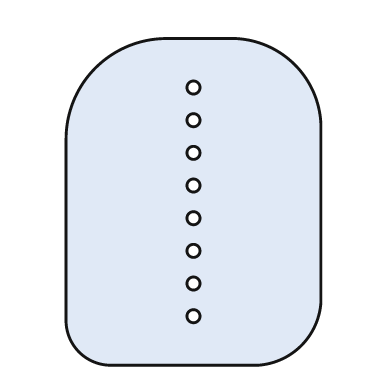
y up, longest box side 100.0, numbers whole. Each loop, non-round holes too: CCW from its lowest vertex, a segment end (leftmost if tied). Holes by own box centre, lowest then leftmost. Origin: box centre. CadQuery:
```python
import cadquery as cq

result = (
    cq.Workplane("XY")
    .moveTo(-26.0, -50.0)
    .lineTo(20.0, -50.0)
    .threePointArc((33.0, -44.0), (39.0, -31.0))
    .lineTo(39.0, 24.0)
    .threePointArc((31.0, 42.0), (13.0, 50.0))
    .lineTo(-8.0, 50.0)
    .threePointArc((-30.0, 41.0), (-39.0, 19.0))
    .lineTo(-39.0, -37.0)
    .threePointArc((-35.0, -46.0), (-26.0, -50.0))
    .close()
    .moveTo(0.0, -35.0)
    .circle(2.0)
    .moveTo(0.0, -25.0)
    .circle(2.0)
    .moveTo(0.0, -15.0)
    .circle(2.0)
    .moveTo(0.0, -5.0)
    .circle(2.0)
    .moveTo(0.0, 5.0)
    .circle(2.0)
    .moveTo(0.0, 15.0)
    .circle(2.0)
    .moveTo(0.0, 25.0)
    .circle(2.0)
    .moveTo(0.0, 35.0)
    .circle(2.0)
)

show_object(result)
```